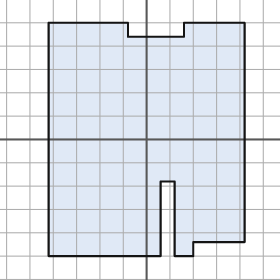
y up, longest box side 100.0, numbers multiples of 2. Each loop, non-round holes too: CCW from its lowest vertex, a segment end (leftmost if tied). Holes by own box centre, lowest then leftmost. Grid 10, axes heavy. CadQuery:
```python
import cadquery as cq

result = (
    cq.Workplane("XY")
    .moveTo(-42.0, -50.0)
    .lineTo(6.0, -50.0)
    .lineTo(6.0, -18.0)
    .lineTo(12.0, -18.0)
    .lineTo(12.0, -50.0)
    .lineTo(20.0, -50.0)
    .lineTo(20.0, -44.0)
    .lineTo(42.0, -44.0)
    .lineTo(42.0, 50.0)
    .lineTo(16.0, 50.0)
    .lineTo(16.0, 44.0)
    .lineTo(-8.0, 44.0)
    .lineTo(-8.0, 50.0)
    .lineTo(-42.0, 50.0)
    .close()
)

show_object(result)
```